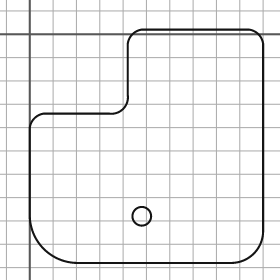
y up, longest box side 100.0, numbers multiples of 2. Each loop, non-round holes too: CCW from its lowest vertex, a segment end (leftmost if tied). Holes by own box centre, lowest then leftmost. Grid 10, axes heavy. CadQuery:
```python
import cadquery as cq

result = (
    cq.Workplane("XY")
    .moveTo(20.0, -98.0)
    .lineTo(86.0, -98.0)
    .threePointArc((96.0, -94.0), (100.0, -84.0))
    .lineTo(100.0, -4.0)
    .threePointArc((98.0, 0.0), (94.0, 2.0))
    .lineTo(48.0, 2.0)
    .threePointArc((44.0, 0.0), (42.0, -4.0))
    .lineTo(42.0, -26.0)
    .threePointArc((40.0, -32.0), (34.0, -34.0))
    .lineTo(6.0, -34.0)
    .threePointArc((2.0, -36.0), (0.0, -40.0))
    .lineTo(0.0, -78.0)
    .threePointArc((6.0, -92.0), (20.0, -98.0))
    .close()
    .moveTo(48.0, -78.0)
    .circle(4.0)
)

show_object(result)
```